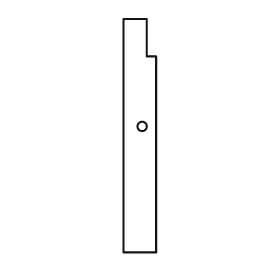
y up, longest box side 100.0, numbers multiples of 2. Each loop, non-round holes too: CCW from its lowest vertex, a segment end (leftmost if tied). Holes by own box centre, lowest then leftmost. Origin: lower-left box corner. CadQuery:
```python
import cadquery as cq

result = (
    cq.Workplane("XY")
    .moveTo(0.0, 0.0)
    .lineTo(14.0, 0.0)
    .lineTo(14.0, 84.0)
    .lineTo(10.0, 84.0)
    .lineTo(10.0, 100.0)
    .lineTo(0.0, 100.0)
    .close()
    .moveTo(8.0, 54.0)
    .circle(2.0)
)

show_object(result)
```